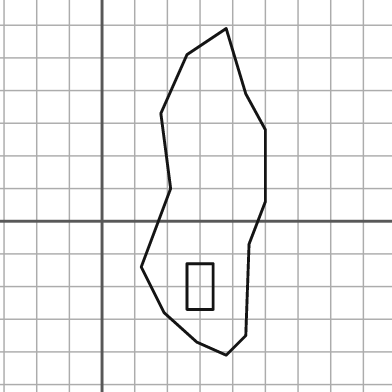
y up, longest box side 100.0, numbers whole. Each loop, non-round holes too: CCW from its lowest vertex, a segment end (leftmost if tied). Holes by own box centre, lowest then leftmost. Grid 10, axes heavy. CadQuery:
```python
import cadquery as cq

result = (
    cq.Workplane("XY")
    .moveTo(38.0, -41.0)
    .lineTo(44.0, -35.0)
    .lineTo(45.0, -7.0)
    .lineTo(50.0, 6.0)
    .lineTo(50.0, 28.0)
    .lineTo(44.0, 39.0)
    .lineTo(38.0, 59.0)
    .lineTo(26.0, 51.0)
    .lineTo(18.0, 33.0)
    .lineTo(21.0, 10.0)
    .lineTo(12.0, -14.0)
    .lineTo(19.0, -28.0)
    .lineTo(29.0, -37.0)
    .close()
    .moveTo(26.0, -27.0)
    .lineTo(34.0, -27.0)
    .lineTo(34.0, -13.0)
    .lineTo(26.0, -13.0)
    .close()
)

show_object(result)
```